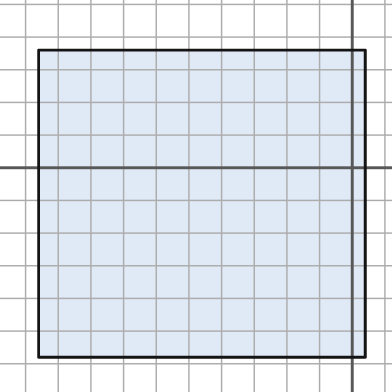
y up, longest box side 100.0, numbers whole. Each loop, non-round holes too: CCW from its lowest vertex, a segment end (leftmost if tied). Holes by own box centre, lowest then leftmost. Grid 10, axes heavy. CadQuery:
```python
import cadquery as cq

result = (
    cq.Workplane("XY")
    .moveTo(-96.0, -58.0)
    .lineTo(4.0, -58.0)
    .lineTo(4.0, 36.0)
    .lineTo(-96.0, 36.0)
    .close()
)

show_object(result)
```